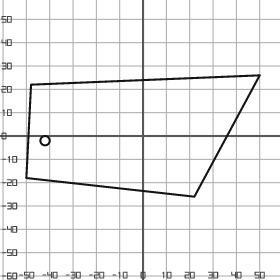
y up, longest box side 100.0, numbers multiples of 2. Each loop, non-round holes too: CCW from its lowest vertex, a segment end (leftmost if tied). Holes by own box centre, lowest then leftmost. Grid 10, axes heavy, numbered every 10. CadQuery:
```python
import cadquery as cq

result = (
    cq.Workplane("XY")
    .moveTo(22.0, -26.0)
    .lineTo(50.0, 26.0)
    .lineTo(-48.0, 22.0)
    .lineTo(-50.0, -18.0)
    .close()
    .moveTo(-42.0, -2.0)
    .circle(2.0)
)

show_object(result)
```